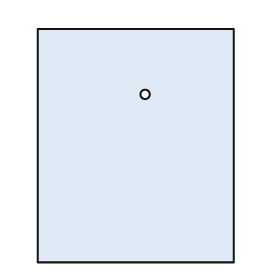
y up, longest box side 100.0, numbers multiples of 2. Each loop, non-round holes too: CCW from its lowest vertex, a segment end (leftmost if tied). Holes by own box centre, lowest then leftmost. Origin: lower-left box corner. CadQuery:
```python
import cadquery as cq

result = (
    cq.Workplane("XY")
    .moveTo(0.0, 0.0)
    .lineTo(84.0, 0.0)
    .lineTo(84.0, 100.0)
    .lineTo(0.0, 100.0)
    .close()
    .moveTo(46.0, 72.0)
    .circle(2.0)
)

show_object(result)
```